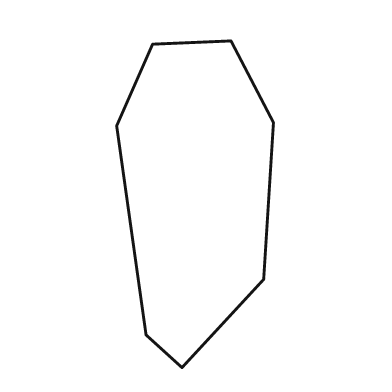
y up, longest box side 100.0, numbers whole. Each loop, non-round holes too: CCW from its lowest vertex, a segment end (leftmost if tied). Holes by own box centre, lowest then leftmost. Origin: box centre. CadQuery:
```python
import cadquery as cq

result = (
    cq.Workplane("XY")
    .moveTo(-4.0, -50.0)
    .lineTo(21.0, -23.0)
    .lineTo(24.0, 25.0)
    .lineTo(11.0, 50.0)
    .lineTo(-13.0, 49.0)
    .lineTo(-24.0, 24.0)
    .lineTo(-15.0, -40.0)
    .close()
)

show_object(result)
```